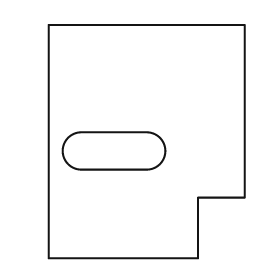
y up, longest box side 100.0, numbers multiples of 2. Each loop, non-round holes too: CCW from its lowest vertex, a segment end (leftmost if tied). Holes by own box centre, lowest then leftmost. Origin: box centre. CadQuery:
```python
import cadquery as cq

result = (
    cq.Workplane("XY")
    .moveTo(-42.0, -50.0)
    .lineTo(22.0, -50.0)
    .lineTo(22.0, -24.0)
    .lineTo(42.0, -24.0)
    .lineTo(42.0, 50.0)
    .lineTo(-42.0, 50.0)
    .close()
    .moveTo(-28.0, -12.0)
    .lineTo(0.0, -12.0)
    .threePointArc((8.0, -4.0), (0.0, 4.0))
    .lineTo(-28.0, 4.0)
    .threePointArc((-36.0, -4.0), (-28.0, -12.0))
    .close()
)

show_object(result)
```